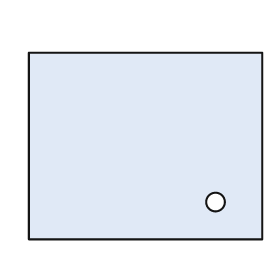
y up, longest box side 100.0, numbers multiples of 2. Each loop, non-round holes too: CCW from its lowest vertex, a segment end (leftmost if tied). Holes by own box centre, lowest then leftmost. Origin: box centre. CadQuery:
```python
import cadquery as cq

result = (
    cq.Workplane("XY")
    .moveTo(-50.0, -40.0)
    .lineTo(50.0, -40.0)
    .lineTo(50.0, 40.0)
    .lineTo(-50.0, 40.0)
    .close()
    .moveTo(30.0, -24.0)
    .circle(4.0)
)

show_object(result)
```